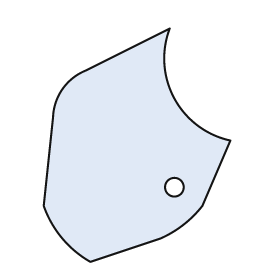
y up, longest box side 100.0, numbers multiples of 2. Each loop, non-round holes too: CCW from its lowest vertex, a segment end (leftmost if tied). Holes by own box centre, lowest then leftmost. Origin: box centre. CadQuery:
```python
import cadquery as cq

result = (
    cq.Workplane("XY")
    .moveTo(-20.0, -50.0)
    .lineTo(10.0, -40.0)
    .threePointArc((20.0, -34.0), (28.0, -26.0))
    .lineTo(40.0, 2.0)
    .threePointArc((16.0, 20.0), (14.0, 50.0))
    .lineTo(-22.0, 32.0)
    .threePointArc((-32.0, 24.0), (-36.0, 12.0))
    .lineTo(-40.0, -26.0)
    .threePointArc((-32.0, -40.0), (-20.0, -50.0))
    .close()
    .moveTo(16.0, -18.0)
    .circle(4.0)
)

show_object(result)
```